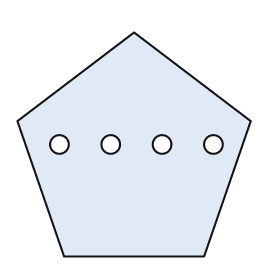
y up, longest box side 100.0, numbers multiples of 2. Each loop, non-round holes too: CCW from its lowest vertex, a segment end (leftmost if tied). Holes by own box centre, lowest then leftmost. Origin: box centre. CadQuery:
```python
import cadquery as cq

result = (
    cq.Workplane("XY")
    .moveTo(-30.0, -48.0)
    .lineTo(30.0, -48.0)
    .lineTo(50.0, 10.0)
    .lineTo(0.0, 48.0)
    .lineTo(-50.0, 10.0)
    .close()
    .moveTo(-32.0, 0.0)
    .circle(4.0)
    .moveTo(-10.0, 0.0)
    .circle(4.0)
    .moveTo(12.0, 0.0)
    .circle(4.0)
    .moveTo(34.0, 0.0)
    .circle(4.0)
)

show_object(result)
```